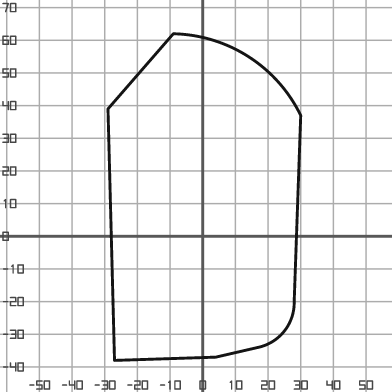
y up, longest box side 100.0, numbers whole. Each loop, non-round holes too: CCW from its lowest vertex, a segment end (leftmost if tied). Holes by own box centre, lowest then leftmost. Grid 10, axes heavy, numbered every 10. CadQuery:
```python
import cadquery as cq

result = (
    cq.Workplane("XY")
    .moveTo(-27.0, -38.0)
    .lineTo(4.0, -37.0)
    .lineTo(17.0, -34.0)
    .threePointArc((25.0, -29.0), (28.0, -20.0))
    .lineTo(30.0, 37.0)
    .threePointArc((14.0, 55.0), (-9.0, 62.0))
    .lineTo(-29.0, 39.0)
    .close()
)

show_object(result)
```